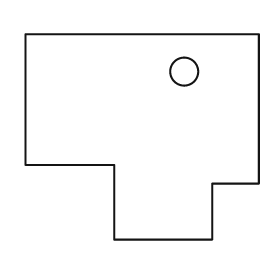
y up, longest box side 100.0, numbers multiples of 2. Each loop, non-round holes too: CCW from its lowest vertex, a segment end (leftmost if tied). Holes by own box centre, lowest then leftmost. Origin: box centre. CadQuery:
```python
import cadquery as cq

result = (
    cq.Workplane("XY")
    .moveTo(-12.0, -44.0)
    .lineTo(30.0, -44.0)
    .lineTo(30.0, -20.0)
    .lineTo(50.0, -20.0)
    .lineTo(50.0, 44.0)
    .lineTo(-50.0, 44.0)
    .lineTo(-50.0, -12.0)
    .lineTo(-12.0, -12.0)
    .close()
    .moveTo(18.0, 28.0)
    .circle(6.0)
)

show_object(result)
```